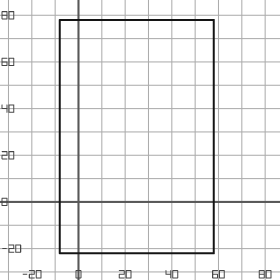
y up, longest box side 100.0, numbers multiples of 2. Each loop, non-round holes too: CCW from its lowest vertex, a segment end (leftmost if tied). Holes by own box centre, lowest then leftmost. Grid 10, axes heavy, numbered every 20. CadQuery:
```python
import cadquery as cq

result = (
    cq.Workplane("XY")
    .moveTo(-8.0, -22.0)
    .lineTo(58.0, -22.0)
    .lineTo(58.0, 78.0)
    .lineTo(-8.0, 78.0)
    .close()
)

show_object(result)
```